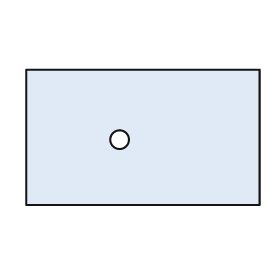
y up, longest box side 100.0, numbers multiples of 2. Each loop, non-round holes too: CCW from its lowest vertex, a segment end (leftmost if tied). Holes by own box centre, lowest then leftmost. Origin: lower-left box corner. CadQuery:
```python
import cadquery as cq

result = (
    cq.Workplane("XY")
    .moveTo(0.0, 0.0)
    .lineTo(100.0, 0.0)
    .lineTo(100.0, 58.0)
    .lineTo(0.0, 58.0)
    .close()
    .moveTo(40.0, 28.0)
    .circle(4.0)
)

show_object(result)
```